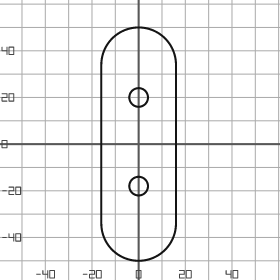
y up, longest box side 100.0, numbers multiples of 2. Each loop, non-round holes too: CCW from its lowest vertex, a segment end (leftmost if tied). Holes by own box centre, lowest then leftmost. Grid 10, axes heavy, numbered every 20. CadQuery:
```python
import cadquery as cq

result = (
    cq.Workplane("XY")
    .moveTo(-16.0, -34.0)
    .threePointArc((0.0, -50.0), (16.0, -34.0))
    .lineTo(16.0, 34.0)
    .threePointArc((0.0, 50.0), (-16.0, 34.0))
    .close()
    .moveTo(0.0, -18.0)
    .circle(4.0)
    .moveTo(0.0, 20.0)
    .circle(4.0)
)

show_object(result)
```